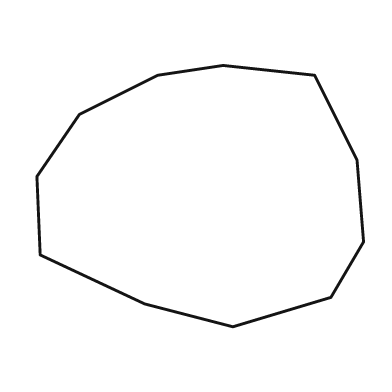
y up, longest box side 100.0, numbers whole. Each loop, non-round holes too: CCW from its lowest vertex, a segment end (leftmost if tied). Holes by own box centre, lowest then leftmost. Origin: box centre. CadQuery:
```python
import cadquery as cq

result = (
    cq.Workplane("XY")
    .moveTo(10.0, -40.0)
    .lineTo(40.0, -31.0)
    .lineTo(50.0, -14.0)
    .lineTo(48.0, 11.0)
    .lineTo(35.0, 37.0)
    .lineTo(7.0, 40.0)
    .lineTo(-13.0, 37.0)
    .lineTo(-37.0, 25.0)
    .lineTo(-50.0, 6.0)
    .lineTo(-49.0, -18.0)
    .lineTo(-17.0, -33.0)
    .close()
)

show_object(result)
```